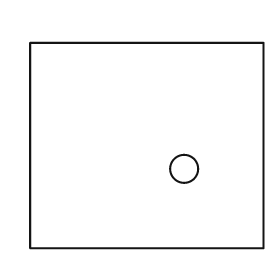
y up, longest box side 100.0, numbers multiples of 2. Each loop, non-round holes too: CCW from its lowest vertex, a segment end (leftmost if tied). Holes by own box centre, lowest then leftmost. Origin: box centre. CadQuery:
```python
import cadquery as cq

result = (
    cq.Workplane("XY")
    .moveTo(-50.0, -44.0)
    .lineTo(50.0, -44.0)
    .lineTo(50.0, 44.0)
    .lineTo(-50.0, 44.0)
    .close()
    .moveTo(16.0, -10.0)
    .circle(6.0)
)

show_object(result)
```